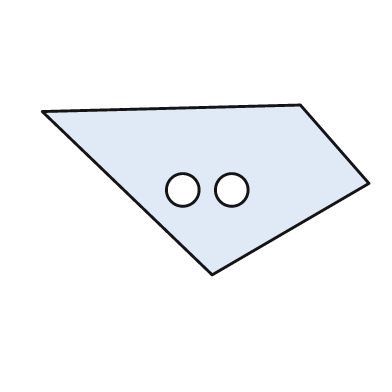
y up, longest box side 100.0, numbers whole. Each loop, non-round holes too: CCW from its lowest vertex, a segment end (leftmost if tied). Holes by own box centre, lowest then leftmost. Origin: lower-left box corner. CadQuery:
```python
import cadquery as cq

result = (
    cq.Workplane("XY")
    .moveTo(52.0, 0.0)
    .lineTo(100.0, 28.0)
    .lineTo(79.0, 52.0)
    .lineTo(0.0, 50.0)
    .close()
    .moveTo(43.0, 26.0)
    .circle(5.0)
    .moveTo(58.0, 26.0)
    .circle(5.0)
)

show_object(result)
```